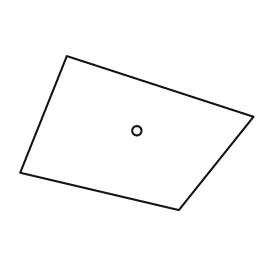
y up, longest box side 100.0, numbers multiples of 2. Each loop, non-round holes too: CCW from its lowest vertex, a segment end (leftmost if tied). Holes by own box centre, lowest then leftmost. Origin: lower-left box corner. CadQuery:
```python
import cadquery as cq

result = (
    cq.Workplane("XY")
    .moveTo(68.0, 0.0)
    .lineTo(100.0, 40.0)
    .lineTo(20.0, 66.0)
    .lineTo(0.0, 16.0)
    .close()
    .moveTo(50.0, 34.0)
    .circle(2.0)
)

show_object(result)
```